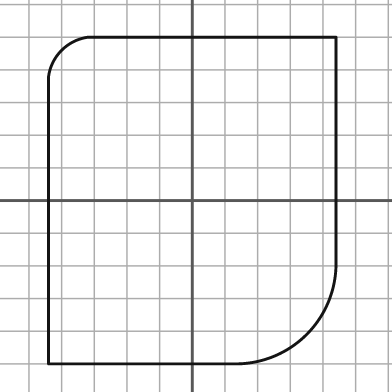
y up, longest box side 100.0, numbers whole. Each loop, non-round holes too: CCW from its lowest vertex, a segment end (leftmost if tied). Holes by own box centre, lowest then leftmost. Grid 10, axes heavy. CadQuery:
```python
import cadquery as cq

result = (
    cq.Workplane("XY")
    .moveTo(-44.0, -50.0)
    .lineTo(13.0, -50.0)
    .threePointArc((35.0, -41.0), (44.0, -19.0))
    .lineTo(44.0, 50.0)
    .lineTo(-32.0, 50.0)
    .threePointArc((-40.0, 46.0), (-44.0, 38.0))
    .close()
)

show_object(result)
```